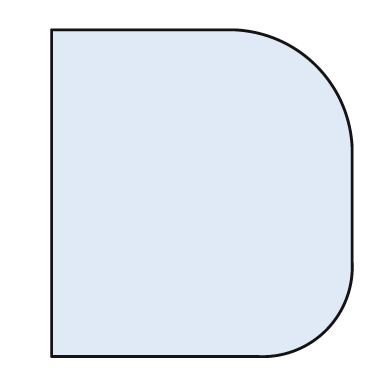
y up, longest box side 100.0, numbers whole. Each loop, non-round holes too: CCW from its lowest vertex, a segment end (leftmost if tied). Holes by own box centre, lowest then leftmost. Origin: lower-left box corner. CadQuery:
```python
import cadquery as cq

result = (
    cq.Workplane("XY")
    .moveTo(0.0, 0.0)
    .lineTo(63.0, 0.0)
    .threePointArc((84.0, 8.0), (92.0, 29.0))
    .lineTo(92.0, 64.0)
    .threePointArc((81.0, 89.0), (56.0, 100.0))
    .lineTo(0.0, 100.0)
    .close()
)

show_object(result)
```